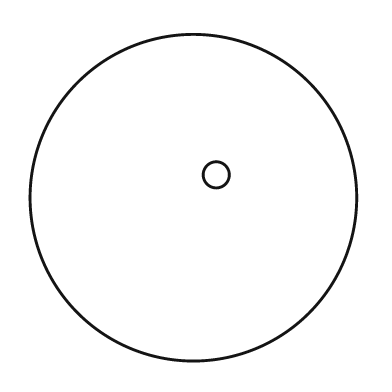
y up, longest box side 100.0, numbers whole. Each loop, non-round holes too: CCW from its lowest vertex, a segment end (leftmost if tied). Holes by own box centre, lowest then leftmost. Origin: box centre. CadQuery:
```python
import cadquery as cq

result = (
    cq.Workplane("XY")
    .moveTo(0.0, 0.0)
    .circle(50.0)
    .moveTo(7.0, 7.0)
    .circle(4.0)
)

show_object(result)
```